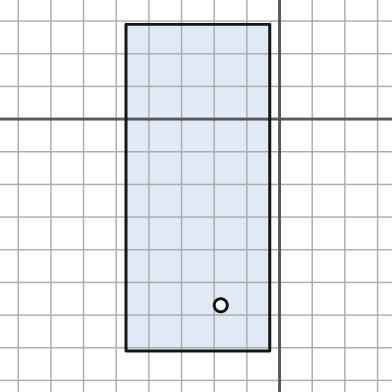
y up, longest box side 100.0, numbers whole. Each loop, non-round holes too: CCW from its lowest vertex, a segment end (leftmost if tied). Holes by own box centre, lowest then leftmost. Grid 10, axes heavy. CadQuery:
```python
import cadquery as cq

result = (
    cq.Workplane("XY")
    .moveTo(-47.0, -71.0)
    .lineTo(-3.0, -71.0)
    .lineTo(-3.0, 29.0)
    .lineTo(-47.0, 29.0)
    .close()
    .moveTo(-18.0, -57.0)
    .circle(2.0)
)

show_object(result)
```